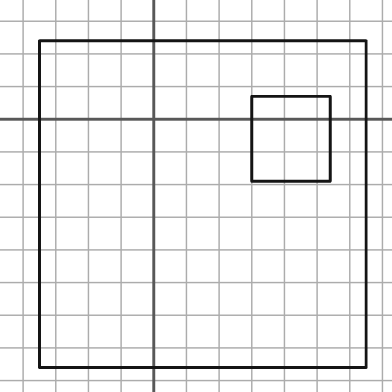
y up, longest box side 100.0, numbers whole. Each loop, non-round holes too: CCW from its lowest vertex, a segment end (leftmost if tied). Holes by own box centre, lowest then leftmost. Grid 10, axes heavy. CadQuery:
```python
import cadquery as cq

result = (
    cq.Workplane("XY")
    .moveTo(-35.0, -76.0)
    .lineTo(65.0, -76.0)
    .lineTo(65.0, 24.0)
    .lineTo(-35.0, 24.0)
    .close()
    .moveTo(30.0, -19.0)
    .lineTo(54.0, -19.0)
    .lineTo(54.0, 7.0)
    .lineTo(30.0, 7.0)
    .close()
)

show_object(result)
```